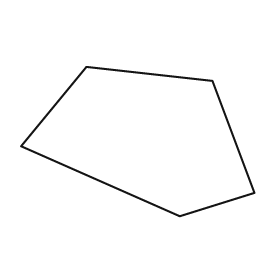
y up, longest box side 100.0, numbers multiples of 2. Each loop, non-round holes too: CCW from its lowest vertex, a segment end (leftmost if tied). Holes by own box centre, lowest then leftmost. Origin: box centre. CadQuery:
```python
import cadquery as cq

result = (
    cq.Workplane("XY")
    .moveTo(18.0, -32.0)
    .lineTo(50.0, -22.0)
    .lineTo(32.0, 26.0)
    .lineTo(-22.0, 32.0)
    .lineTo(-50.0, -2.0)
    .close()
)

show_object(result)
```